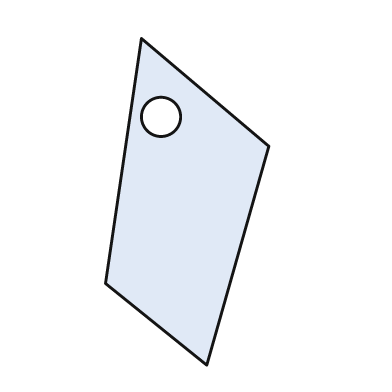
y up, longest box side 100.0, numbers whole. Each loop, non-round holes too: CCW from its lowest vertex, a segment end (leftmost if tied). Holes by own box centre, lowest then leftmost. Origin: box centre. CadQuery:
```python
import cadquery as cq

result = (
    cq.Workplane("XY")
    .moveTo(6.0, -50.0)
    .lineTo(25.0, 17.0)
    .lineTo(-14.0, 50.0)
    .lineTo(-25.0, -25.0)
    .close()
    .moveTo(-8.0, 26.0)
    .circle(6.0)
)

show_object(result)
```